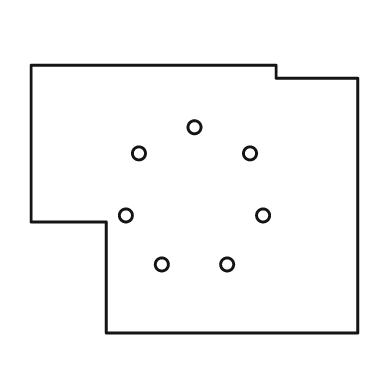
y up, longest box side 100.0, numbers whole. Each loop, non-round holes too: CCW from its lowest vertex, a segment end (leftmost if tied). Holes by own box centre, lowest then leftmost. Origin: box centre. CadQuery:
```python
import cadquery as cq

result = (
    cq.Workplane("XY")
    .moveTo(-27.0, -41.0)
    .lineTo(50.0, -41.0)
    .lineTo(50.0, 37.0)
    .lineTo(25.0, 37.0)
    .lineTo(25.0, 41.0)
    .lineTo(-50.0, 41.0)
    .lineTo(-50.0, -7.0)
    .lineTo(-27.0, -7.0)
    .close()
    .moveTo(-10.0, -20.0)
    .circle(2.0)
    .moveTo(10.0, -20.0)
    .circle(2.0)
    .moveTo(-21.0, -5.0)
    .circle(2.0)
    .moveTo(21.0, -5.0)
    .circle(2.0)
    .moveTo(-17.0, 14.0)
    .circle(2.0)
    .moveTo(17.0, 14.0)
    .circle(2.0)
    .moveTo(0.0, 22.0)
    .circle(2.0)
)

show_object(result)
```